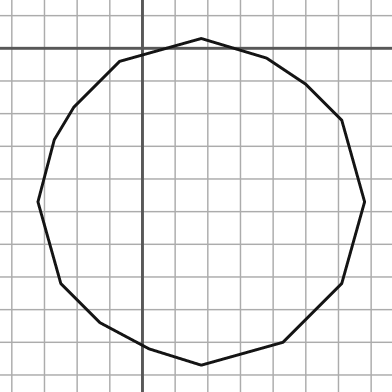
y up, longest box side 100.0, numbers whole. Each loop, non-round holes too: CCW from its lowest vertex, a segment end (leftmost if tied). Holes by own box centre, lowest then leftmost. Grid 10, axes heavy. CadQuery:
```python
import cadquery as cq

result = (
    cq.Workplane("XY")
    .moveTo(18.0, -97.0)
    .lineTo(43.0, -90.0)
    .lineTo(61.0, -72.0)
    .lineTo(68.0, -47.0)
    .lineTo(61.0, -22.0)
    .lineTo(50.0, -11.0)
    .lineTo(38.0, -3.0)
    .lineTo(18.0, 3.0)
    .lineTo(-7.0, -4.0)
    .lineTo(-21.0, -18.0)
    .lineTo(-27.0, -28.0)
    .lineTo(-32.0, -47.0)
    .lineTo(-25.0, -72.0)
    .lineTo(-13.0, -84.0)
    .lineTo(2.0, -92.0)
    .close()
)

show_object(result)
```